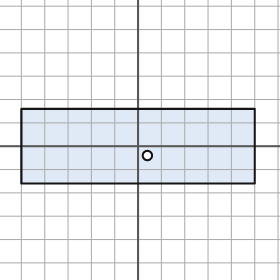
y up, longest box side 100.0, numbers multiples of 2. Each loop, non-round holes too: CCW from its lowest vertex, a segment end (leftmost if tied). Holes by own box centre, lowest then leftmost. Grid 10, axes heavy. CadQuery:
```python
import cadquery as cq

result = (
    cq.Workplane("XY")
    .moveTo(-50.0, -16.0)
    .lineTo(50.0, -16.0)
    .lineTo(50.0, 16.0)
    .lineTo(-50.0, 16.0)
    .close()
    .moveTo(4.0, -4.0)
    .circle(2.0)
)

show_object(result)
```